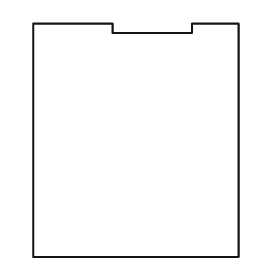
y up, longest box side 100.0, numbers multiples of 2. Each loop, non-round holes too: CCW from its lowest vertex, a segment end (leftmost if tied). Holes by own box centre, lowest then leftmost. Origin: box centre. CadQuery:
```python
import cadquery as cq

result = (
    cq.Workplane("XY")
    .moveTo(-44.0, -50.0)
    .lineTo(44.0, -50.0)
    .lineTo(44.0, 50.0)
    .lineTo(24.0, 50.0)
    .lineTo(24.0, 46.0)
    .lineTo(-10.0, 46.0)
    .lineTo(-10.0, 50.0)
    .lineTo(-44.0, 50.0)
    .close()
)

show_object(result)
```